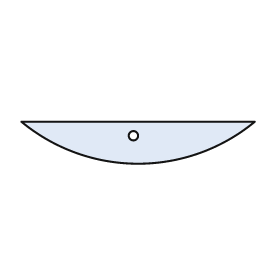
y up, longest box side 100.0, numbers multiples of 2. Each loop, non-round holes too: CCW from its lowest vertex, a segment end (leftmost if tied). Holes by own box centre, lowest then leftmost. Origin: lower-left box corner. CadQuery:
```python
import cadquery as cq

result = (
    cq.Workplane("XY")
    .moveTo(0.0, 18.0)
    .threePointArc((50.0, 0.0), (100.0, 18.0))
    .close()
    .moveTo(48.0, 12.0)
    .circle(2.0)
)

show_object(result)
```